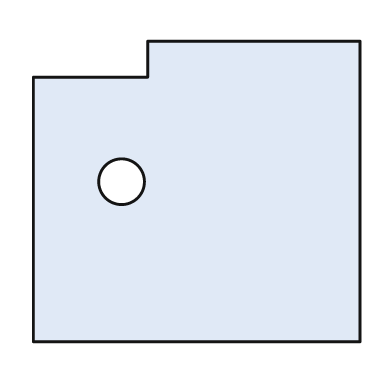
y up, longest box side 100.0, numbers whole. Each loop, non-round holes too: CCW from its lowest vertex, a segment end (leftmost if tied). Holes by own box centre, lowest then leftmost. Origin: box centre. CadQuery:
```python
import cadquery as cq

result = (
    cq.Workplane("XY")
    .moveTo(-50.0, -46.0)
    .lineTo(50.0, -46.0)
    .lineTo(50.0, 46.0)
    .lineTo(-15.0, 46.0)
    .lineTo(-15.0, 35.0)
    .lineTo(-50.0, 35.0)
    .close()
    .moveTo(-23.0, 3.0)
    .circle(7.0)
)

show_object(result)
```